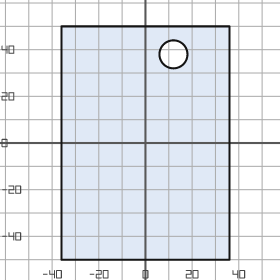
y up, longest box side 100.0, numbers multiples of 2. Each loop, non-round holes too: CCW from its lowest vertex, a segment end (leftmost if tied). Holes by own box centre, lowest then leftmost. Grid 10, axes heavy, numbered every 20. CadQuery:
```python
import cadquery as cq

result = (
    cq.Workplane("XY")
    .moveTo(-36.0, -50.0)
    .lineTo(36.0, -50.0)
    .lineTo(36.0, 50.0)
    .lineTo(-36.0, 50.0)
    .close()
    .moveTo(12.0, 38.0)
    .circle(6.0)
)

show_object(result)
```